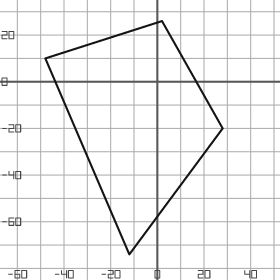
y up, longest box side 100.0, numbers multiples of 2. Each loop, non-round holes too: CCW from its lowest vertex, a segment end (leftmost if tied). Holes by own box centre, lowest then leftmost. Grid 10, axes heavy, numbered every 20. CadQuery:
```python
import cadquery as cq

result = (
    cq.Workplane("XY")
    .moveTo(-12.0, -74.0)
    .lineTo(28.0, -20.0)
    .lineTo(2.0, 26.0)
    .lineTo(-48.0, 10.0)
    .close()
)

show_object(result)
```